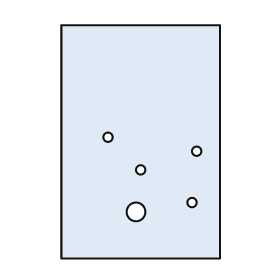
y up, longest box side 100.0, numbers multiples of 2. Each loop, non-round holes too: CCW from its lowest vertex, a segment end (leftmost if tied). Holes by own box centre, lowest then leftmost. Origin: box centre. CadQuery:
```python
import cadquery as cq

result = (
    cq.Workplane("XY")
    .moveTo(-34.0, -50.0)
    .lineTo(34.0, -50.0)
    .lineTo(34.0, 50.0)
    .lineTo(-34.0, 50.0)
    .close()
    .moveTo(-2.0, -30.0)
    .circle(4.0)
    .moveTo(22.0, -26.0)
    .circle(2.0)
    .moveTo(0.0, -12.0)
    .circle(2.0)
    .moveTo(24.0, -4.0)
    .circle(2.0)
    .moveTo(-14.0, 2.0)
    .circle(2.0)
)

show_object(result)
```